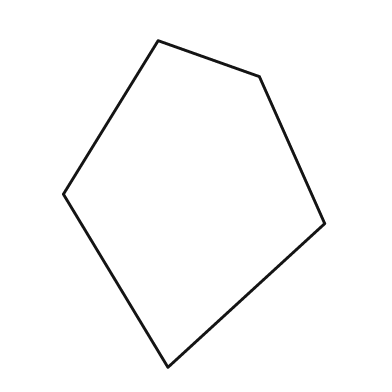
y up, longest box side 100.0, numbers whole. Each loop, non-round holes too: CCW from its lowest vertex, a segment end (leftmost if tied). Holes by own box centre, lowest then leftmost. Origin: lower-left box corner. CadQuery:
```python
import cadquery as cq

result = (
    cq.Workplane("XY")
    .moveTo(32.0, 0.0)
    .lineTo(80.0, 44.0)
    .lineTo(60.0, 89.0)
    .lineTo(29.0, 100.0)
    .lineTo(0.0, 53.0)
    .close()
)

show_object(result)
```